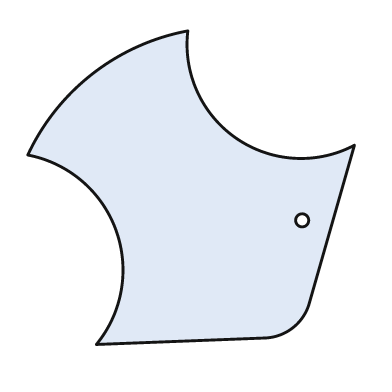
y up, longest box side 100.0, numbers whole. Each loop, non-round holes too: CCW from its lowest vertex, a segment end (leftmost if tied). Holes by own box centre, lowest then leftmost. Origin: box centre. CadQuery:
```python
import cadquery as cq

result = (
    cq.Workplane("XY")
    .moveTo(-29.0, -48.0)
    .lineTo(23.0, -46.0)
    .threePointArc((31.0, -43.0), (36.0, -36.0))
    .lineTo(50.0, 13.0)
    .threePointArc((14.0, 15.0), (-1.0, 48.0))
    .threePointArc((-30.0, 35.0), (-50.0, 10.0))
    .threePointArc((-23.0, -13.0), (-29.0, -48.0))
    .close()
    .moveTo(34.0, -10.0)
    .circle(2.0)
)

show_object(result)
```